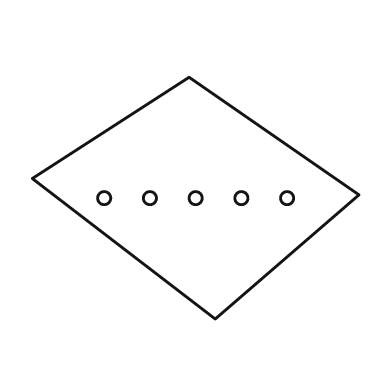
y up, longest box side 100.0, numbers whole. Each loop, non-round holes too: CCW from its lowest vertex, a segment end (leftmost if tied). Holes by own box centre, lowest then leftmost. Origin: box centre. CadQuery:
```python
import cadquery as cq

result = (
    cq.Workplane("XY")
    .moveTo(6.0, -37.0)
    .lineTo(50.0, 1.0)
    .lineTo(-2.0, 37.0)
    .lineTo(-50.0, 6.0)
    .close()
    .moveTo(-28.0, 0.0)
    .circle(2.0)
    .moveTo(-14.0, 0.0)
    .circle(2.0)
    .moveTo(0.0, 0.0)
    .circle(2.0)
    .moveTo(14.0, 0.0)
    .circle(2.0)
    .moveTo(28.0, 0.0)
    .circle(2.0)
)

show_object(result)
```